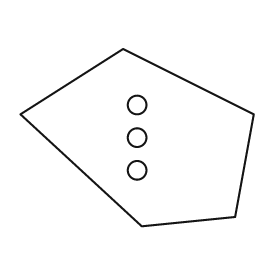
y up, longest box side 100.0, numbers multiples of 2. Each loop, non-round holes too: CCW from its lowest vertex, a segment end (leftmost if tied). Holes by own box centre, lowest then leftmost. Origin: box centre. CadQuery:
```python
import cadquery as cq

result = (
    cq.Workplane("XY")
    .moveTo(2.0, -38.0)
    .lineTo(42.0, -34.0)
    .lineTo(50.0, 10.0)
    .lineTo(-6.0, 38.0)
    .lineTo(-50.0, 10.0)
    .close()
    .moveTo(0.0, -14.0)
    .circle(4.0)
    .moveTo(0.0, 0.0)
    .circle(4.0)
    .moveTo(0.0, 14.0)
    .circle(4.0)
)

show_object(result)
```